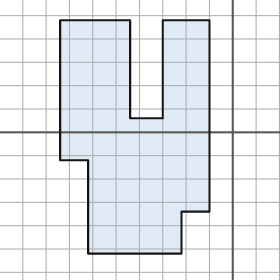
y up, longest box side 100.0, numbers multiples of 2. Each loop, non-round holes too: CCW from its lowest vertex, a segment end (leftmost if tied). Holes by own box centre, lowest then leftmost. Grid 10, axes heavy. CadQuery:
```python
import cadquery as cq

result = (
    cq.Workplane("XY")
    .moveTo(-62.0, -52.0)
    .lineTo(-22.0, -52.0)
    .lineTo(-22.0, -34.0)
    .lineTo(-10.0, -34.0)
    .lineTo(-10.0, 48.0)
    .lineTo(-30.0, 48.0)
    .lineTo(-30.0, 6.0)
    .lineTo(-44.0, 6.0)
    .lineTo(-44.0, 48.0)
    .lineTo(-74.0, 48.0)
    .lineTo(-74.0, -12.0)
    .lineTo(-62.0, -12.0)
    .close()
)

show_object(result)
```